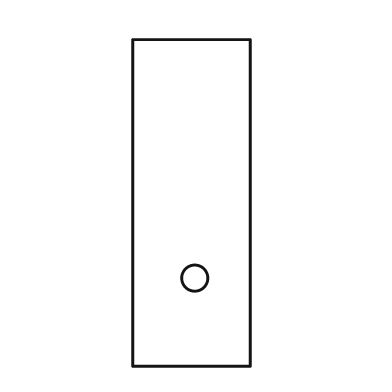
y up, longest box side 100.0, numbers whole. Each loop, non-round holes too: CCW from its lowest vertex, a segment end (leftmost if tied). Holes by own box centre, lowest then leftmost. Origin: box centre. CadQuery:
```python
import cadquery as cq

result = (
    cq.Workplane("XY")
    .moveTo(-18.0, -50.0)
    .lineTo(18.0, -50.0)
    .lineTo(18.0, 50.0)
    .lineTo(-18.0, 50.0)
    .close()
    .moveTo(1.0, -23.0)
    .circle(4.0)
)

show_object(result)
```